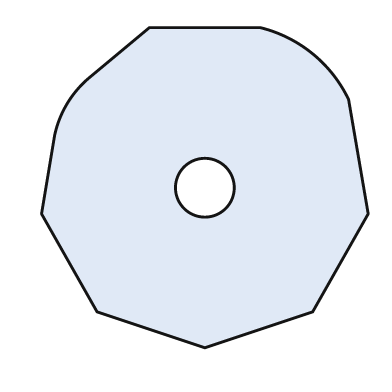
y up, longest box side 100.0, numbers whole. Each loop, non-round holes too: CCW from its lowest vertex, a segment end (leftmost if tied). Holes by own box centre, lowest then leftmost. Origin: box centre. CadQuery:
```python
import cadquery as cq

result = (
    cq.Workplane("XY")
    .moveTo(0.0, -49.0)
    .lineTo(33.0, -38.0)
    .lineTo(50.0, -8.0)
    .lineTo(44.0, 27.0)
    .threePointArc((33.0, 41.0), (17.0, 49.0))
    .lineTo(-17.0, 49.0)
    .lineTo(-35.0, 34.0)
    .threePointArc((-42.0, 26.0), (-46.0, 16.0))
    .lineTo(-50.0, -8.0)
    .lineTo(-33.0, -38.0)
    .close()
    .moveTo(0.0, 0.0)
    .circle(9.0)
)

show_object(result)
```